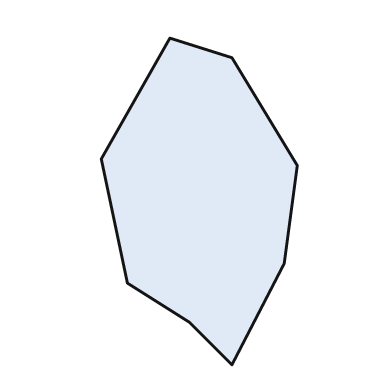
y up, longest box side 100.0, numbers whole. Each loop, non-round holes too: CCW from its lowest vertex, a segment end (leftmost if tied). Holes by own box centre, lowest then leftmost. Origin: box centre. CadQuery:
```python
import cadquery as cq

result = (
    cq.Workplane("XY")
    .moveTo(10.0, -50.0)
    .lineTo(26.0, -19.0)
    .lineTo(30.0, 11.0)
    .lineTo(10.0, 44.0)
    .lineTo(-9.0, 50.0)
    .lineTo(-30.0, 13.0)
    .lineTo(-22.0, -25.0)
    .lineTo(-3.0, -37.0)
    .close()
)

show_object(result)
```